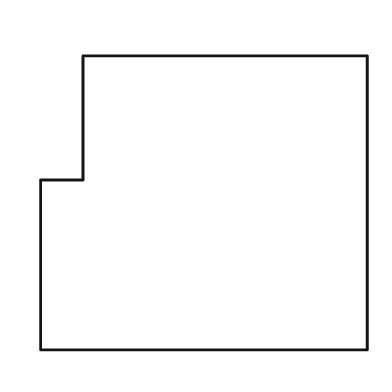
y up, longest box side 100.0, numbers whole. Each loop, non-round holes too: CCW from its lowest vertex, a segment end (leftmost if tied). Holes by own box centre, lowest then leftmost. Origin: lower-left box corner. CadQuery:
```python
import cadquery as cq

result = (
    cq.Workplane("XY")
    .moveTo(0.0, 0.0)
    .lineTo(100.0, 0.0)
    .lineTo(100.0, 90.0)
    .lineTo(13.0, 90.0)
    .lineTo(13.0, 52.0)
    .lineTo(0.0, 52.0)
    .close()
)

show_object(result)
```